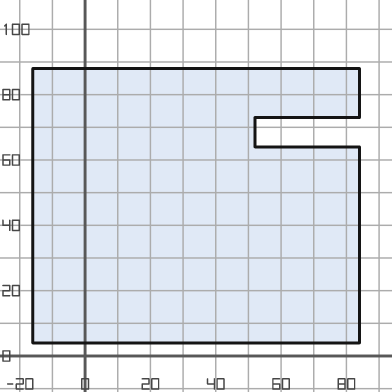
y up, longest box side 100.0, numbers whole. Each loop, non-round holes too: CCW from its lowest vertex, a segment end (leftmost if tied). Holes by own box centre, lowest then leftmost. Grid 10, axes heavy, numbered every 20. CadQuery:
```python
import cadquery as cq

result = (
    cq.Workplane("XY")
    .moveTo(-16.0, 4.0)
    .lineTo(84.0, 4.0)
    .lineTo(84.0, 64.0)
    .lineTo(52.0, 64.0)
    .lineTo(52.0, 73.0)
    .lineTo(84.0, 73.0)
    .lineTo(84.0, 88.0)
    .lineTo(-16.0, 88.0)
    .close()
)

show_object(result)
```